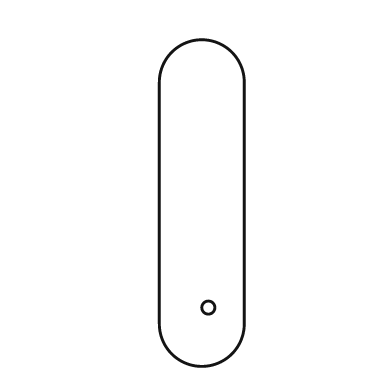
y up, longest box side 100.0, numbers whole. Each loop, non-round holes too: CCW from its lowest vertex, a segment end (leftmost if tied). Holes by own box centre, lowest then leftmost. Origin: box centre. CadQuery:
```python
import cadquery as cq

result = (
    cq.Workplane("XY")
    .moveTo(-13.0, -37.0)
    .threePointArc((0.0, -50.0), (13.0, -37.0))
    .lineTo(13.0, 37.0)
    .threePointArc((0.0, 50.0), (-13.0, 37.0))
    .close()
    .moveTo(2.0, -32.0)
    .circle(2.0)
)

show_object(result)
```